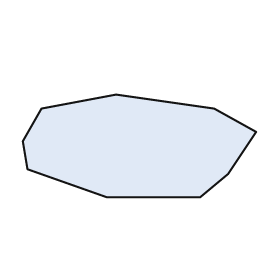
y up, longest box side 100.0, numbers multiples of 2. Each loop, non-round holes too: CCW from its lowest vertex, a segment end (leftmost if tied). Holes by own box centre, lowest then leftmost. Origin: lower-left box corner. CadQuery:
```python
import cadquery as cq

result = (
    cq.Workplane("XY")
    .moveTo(36.0, 0.0)
    .lineTo(76.0, 0.0)
    .lineTo(88.0, 10.0)
    .lineTo(100.0, 28.0)
    .lineTo(82.0, 38.0)
    .lineTo(40.0, 44.0)
    .lineTo(8.0, 38.0)
    .lineTo(0.0, 24.0)
    .lineTo(2.0, 12.0)
    .close()
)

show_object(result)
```